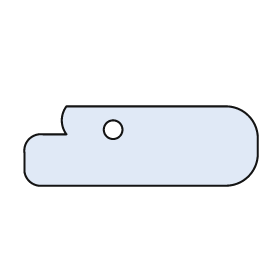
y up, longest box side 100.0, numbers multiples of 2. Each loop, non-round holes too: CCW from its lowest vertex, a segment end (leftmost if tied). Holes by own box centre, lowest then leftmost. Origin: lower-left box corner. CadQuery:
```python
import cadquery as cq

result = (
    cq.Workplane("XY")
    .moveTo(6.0, 0.0)
    .lineTo(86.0, 0.0)
    .threePointArc((96.0, 4.0), (100.0, 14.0))
    .lineTo(100.0, 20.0)
    .threePointArc((96.0, 30.0), (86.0, 34.0))
    .lineTo(18.0, 34.0)
    .threePointArc((16.0, 28.0), (18.0, 22.0))
    .lineTo(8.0, 22.0)
    .threePointArc((2.0, 20.0), (0.0, 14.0))
    .lineTo(0.0, 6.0)
    .threePointArc((2.0, 2.0), (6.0, 0.0))
    .close()
    .moveTo(38.0, 24.0)
    .circle(4.0)
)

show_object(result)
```